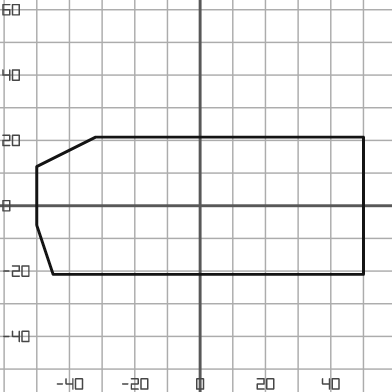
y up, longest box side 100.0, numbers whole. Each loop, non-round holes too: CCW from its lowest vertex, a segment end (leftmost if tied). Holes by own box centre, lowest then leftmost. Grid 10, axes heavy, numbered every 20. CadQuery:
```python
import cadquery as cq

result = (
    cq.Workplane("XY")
    .moveTo(-45.0, -21.0)
    .lineTo(50.0, -21.0)
    .lineTo(50.0, 21.0)
    .lineTo(-32.0, 21.0)
    .lineTo(-50.0, 12.0)
    .lineTo(-50.0, -6.0)
    .close()
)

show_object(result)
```